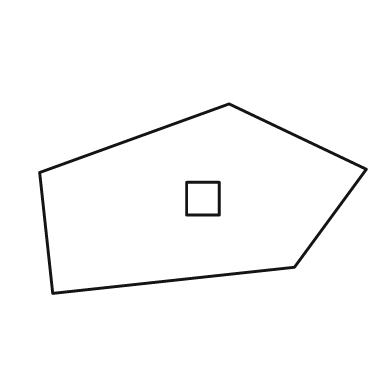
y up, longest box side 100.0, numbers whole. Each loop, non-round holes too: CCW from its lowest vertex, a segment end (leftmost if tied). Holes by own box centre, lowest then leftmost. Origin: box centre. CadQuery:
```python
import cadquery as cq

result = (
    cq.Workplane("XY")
    .moveTo(-46.0, -29.0)
    .lineTo(28.0, -21.0)
    .lineTo(50.0, 9.0)
    .lineTo(8.0, 29.0)
    .lineTo(-50.0, 8.0)
    .close()
    .moveTo(-5.0, -5.0)
    .lineTo(5.0, -5.0)
    .lineTo(5.0, 5.0)
    .lineTo(-5.0, 5.0)
    .close()
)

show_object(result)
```